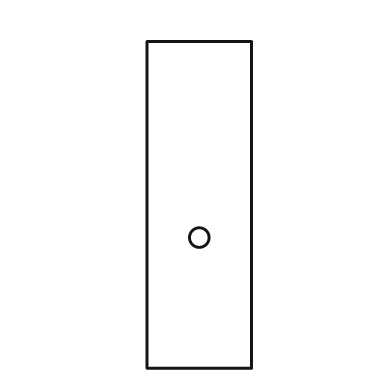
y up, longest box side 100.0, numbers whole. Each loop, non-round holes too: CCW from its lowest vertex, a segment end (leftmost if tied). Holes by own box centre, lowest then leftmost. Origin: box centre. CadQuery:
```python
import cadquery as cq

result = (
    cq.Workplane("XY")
    .moveTo(-16.0, -50.0)
    .lineTo(16.0, -50.0)
    .lineTo(16.0, 50.0)
    .lineTo(-16.0, 50.0)
    .close()
    .moveTo(0.0, -10.0)
    .circle(3.0)
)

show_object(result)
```